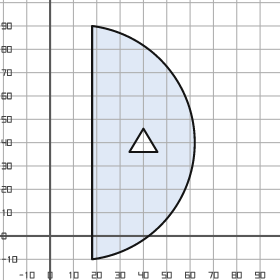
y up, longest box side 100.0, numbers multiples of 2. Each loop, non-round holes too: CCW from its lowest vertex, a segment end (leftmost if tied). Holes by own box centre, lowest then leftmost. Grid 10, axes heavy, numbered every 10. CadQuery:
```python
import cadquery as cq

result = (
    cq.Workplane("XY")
    .moveTo(18.0, -10.0)
    .threePointArc((62.0, 40.0), (18.0, 90.0))
    .close()
    .moveTo(34.0, 36.0)
    .lineTo(46.0, 36.0)
    .lineTo(40.0, 46.0)
    .close()
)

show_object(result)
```